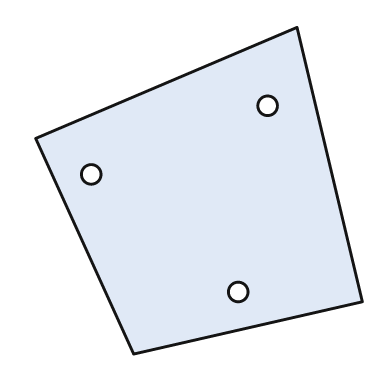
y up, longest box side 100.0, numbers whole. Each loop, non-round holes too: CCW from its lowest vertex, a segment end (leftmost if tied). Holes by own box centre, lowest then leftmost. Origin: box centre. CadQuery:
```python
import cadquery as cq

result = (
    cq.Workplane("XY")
    .moveTo(-20.0, -50.0)
    .lineTo(50.0, -34.0)
    .lineTo(30.0, 50.0)
    .lineTo(-50.0, 16.0)
    .close()
    .moveTo(12.0, -31.0)
    .circle(3.0)
    .moveTo(-33.0, 5.0)
    .circle(3.0)
    .moveTo(21.0, 26.0)
    .circle(3.0)
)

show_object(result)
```